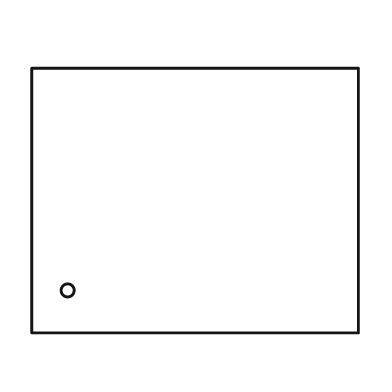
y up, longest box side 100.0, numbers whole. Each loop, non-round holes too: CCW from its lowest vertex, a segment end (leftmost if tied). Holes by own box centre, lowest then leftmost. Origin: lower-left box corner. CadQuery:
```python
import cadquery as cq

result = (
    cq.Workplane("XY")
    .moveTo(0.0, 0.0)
    .lineTo(100.0, 0.0)
    .lineTo(100.0, 81.0)
    .lineTo(0.0, 81.0)
    .close()
    .moveTo(11.0, 13.0)
    .circle(2.0)
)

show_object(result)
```